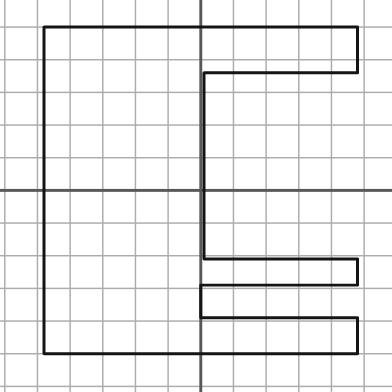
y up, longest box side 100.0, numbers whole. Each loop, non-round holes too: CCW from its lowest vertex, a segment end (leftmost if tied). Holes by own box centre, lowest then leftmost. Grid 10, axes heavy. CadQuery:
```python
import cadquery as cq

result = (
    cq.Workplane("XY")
    .moveTo(-48.0, -50.0)
    .lineTo(48.0, -50.0)
    .lineTo(48.0, -39.0)
    .lineTo(0.0, -39.0)
    .lineTo(0.0, -29.0)
    .lineTo(48.0, -29.0)
    .lineTo(48.0, -21.0)
    .lineTo(1.0, -21.0)
    .lineTo(1.0, 36.0)
    .lineTo(48.0, 36.0)
    .lineTo(48.0, 50.0)
    .lineTo(-48.0, 50.0)
    .close()
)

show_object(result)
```